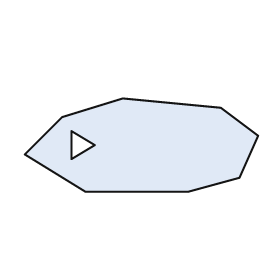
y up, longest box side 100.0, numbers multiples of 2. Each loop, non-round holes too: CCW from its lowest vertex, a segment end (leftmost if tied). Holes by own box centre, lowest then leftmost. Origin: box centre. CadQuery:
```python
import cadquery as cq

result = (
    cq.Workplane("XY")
    .moveTo(-24.0, -20.0)
    .lineTo(20.0, -20.0)
    .lineTo(42.0, -14.0)
    .lineTo(50.0, 4.0)
    .lineTo(34.0, 16.0)
    .lineTo(-8.0, 20.0)
    .lineTo(-34.0, 12.0)
    .lineTo(-50.0, -4.0)
    .close()
    .moveTo(-30.0, -6.0)
    .lineTo(-20.0, 0.0)
    .lineTo(-30.0, 6.0)
    .close()
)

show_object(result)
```